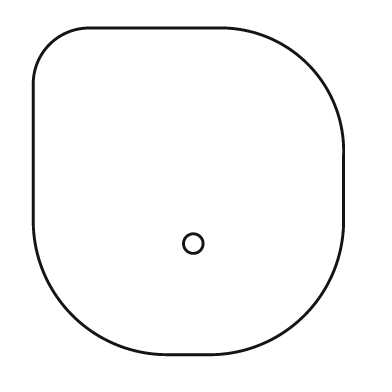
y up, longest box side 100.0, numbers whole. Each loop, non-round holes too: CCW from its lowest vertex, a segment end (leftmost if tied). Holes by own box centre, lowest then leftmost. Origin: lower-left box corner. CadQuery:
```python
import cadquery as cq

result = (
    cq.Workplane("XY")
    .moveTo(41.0, 0.0)
    .lineTo(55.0, 0.0)
    .threePointArc((83.0, 12.0), (95.0, 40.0))
    .lineTo(95.0, 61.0)
    .threePointArc((84.0, 89.0), (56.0, 100.0))
    .lineTo(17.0, 100.0)
    .threePointArc((5.0, 95.0), (0.0, 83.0))
    .lineTo(0.0, 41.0)
    .threePointArc((12.0, 12.0), (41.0, 0.0))
    .close()
    .moveTo(49.0, 34.0)
    .circle(3.0)
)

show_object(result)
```